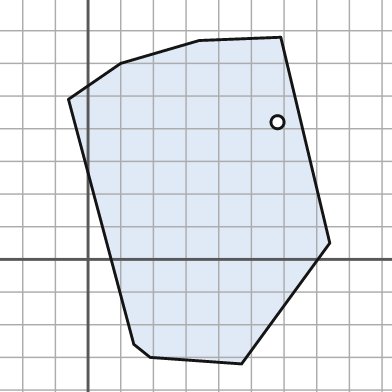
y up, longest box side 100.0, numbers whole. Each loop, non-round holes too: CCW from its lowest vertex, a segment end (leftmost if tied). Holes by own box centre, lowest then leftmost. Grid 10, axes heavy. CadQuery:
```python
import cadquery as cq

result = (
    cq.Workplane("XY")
    .moveTo(47.0, -32.0)
    .lineTo(74.0, 5.0)
    .lineTo(59.0, 68.0)
    .lineTo(34.0, 67.0)
    .lineTo(10.0, 60.0)
    .lineTo(-6.0, 49.0)
    .lineTo(14.0, -26.0)
    .lineTo(19.0, -30.0)
    .close()
    .moveTo(58.0, 42.0)
    .circle(2.0)
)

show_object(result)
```